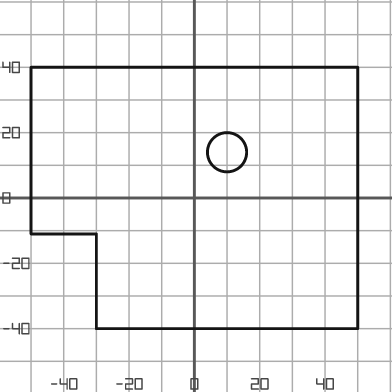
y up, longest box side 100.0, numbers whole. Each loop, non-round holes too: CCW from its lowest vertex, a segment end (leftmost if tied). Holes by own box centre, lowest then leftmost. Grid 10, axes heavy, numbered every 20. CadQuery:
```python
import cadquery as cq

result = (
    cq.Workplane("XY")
    .moveTo(-30.0, -40.0)
    .lineTo(50.0, -40.0)
    .lineTo(50.0, 40.0)
    .lineTo(-50.0, 40.0)
    .lineTo(-50.0, -11.0)
    .lineTo(-30.0, -11.0)
    .close()
    .moveTo(10.0, 14.0)
    .circle(6.0)
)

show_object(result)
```